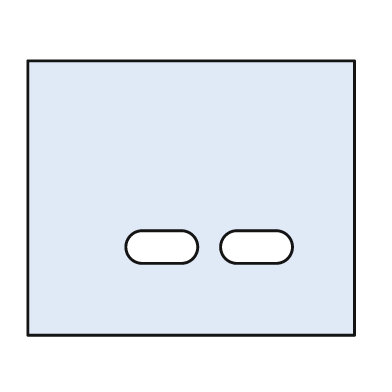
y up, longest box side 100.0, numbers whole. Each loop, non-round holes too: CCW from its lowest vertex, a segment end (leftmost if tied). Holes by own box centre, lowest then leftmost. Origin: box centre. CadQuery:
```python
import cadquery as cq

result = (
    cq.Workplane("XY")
    .moveTo(-50.0, -42.0)
    .lineTo(50.0, -42.0)
    .lineTo(50.0, 42.0)
    .lineTo(-50.0, 42.0)
    .close()
    .moveTo(-15.0, -20.0)
    .lineTo(-3.0, -20.0)
    .threePointArc((2.0, -15.0), (-3.0, -10.0))
    .lineTo(-15.0, -10.0)
    .threePointArc((-20.0, -15.0), (-15.0, -20.0))
    .close()
    .moveTo(14.0, -20.0)
    .lineTo(26.0, -20.0)
    .threePointArc((31.0, -15.0), (26.0, -10.0))
    .lineTo(14.0, -10.0)
    .threePointArc((9.0, -15.0), (14.0, -20.0))
    .close()
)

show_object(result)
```